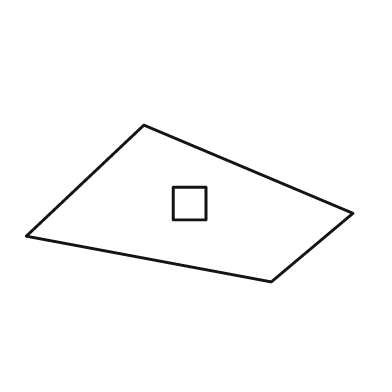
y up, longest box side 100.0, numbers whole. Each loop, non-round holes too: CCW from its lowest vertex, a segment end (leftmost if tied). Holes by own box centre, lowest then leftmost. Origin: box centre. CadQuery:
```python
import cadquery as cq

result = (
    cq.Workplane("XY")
    .moveTo(25.0, -24.0)
    .lineTo(50.0, -3.0)
    .lineTo(-14.0, 24.0)
    .lineTo(-50.0, -10.0)
    .close()
    .moveTo(-5.0, -5.0)
    .lineTo(5.0, -5.0)
    .lineTo(5.0, 5.0)
    .lineTo(-5.0, 5.0)
    .close()
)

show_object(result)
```